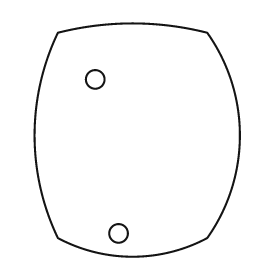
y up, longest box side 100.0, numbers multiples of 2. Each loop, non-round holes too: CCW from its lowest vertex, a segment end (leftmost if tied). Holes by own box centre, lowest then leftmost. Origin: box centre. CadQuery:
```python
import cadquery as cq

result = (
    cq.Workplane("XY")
    .moveTo(-34.0, -42.0)
    .threePointArc((-2.0, -50.0), (30.0, -42.0))
    .threePointArc((44.0, 2.0), (30.0, 46.0))
    .threePointArc((-2.0, 50.0), (-34.0, 46.0))
    .threePointArc((-44.0, 2.0), (-34.0, -42.0))
    .close()
    .moveTo(-8.0, -40.0)
    .circle(4.0)
    .moveTo(-18.0, 26.0)
    .circle(4.0)
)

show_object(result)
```